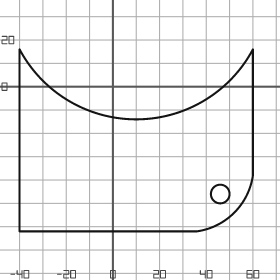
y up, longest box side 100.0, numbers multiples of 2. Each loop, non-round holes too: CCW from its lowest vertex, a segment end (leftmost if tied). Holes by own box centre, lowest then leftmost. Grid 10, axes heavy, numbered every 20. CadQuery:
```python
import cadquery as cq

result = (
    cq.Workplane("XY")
    .moveTo(-40.0, -62.0)
    .lineTo(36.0, -62.0)
    .threePointArc((52.0, -54.0), (60.0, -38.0))
    .lineTo(60.0, 16.0)
    .threePointArc((10.0, -14.0), (-40.0, 16.0))
    .close()
    .moveTo(46.0, -46.0)
    .circle(4.0)
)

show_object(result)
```